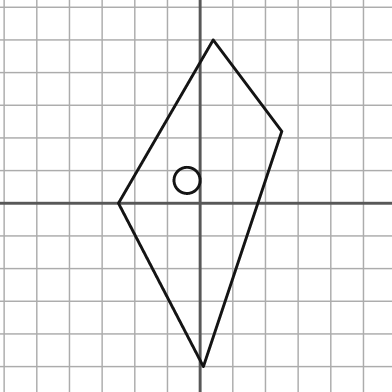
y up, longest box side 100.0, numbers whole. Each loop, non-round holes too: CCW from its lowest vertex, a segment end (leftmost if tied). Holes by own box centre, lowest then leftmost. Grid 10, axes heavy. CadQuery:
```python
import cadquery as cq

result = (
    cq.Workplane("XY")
    .moveTo(1.0, -50.0)
    .lineTo(25.0, 22.0)
    .lineTo(4.0, 50.0)
    .lineTo(-25.0, 0.0)
    .close()
    .moveTo(-4.0, 7.0)
    .circle(4.0)
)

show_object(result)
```